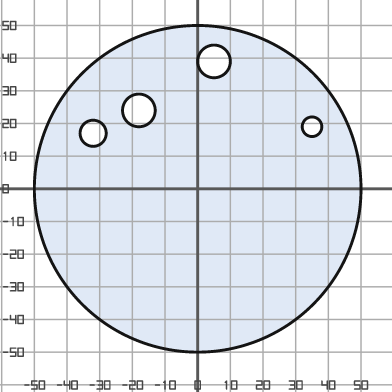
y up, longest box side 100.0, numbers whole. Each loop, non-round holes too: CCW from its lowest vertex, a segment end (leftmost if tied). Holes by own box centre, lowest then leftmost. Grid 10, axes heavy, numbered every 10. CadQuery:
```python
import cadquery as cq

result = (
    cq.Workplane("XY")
    .moveTo(0.0, 0.0)
    .circle(50.0)
    .moveTo(-32.0, 17.0)
    .circle(4.0)
    .moveTo(35.0, 19.0)
    .circle(3.0)
    .moveTo(-18.0, 24.0)
    .circle(5.0)
    .moveTo(5.0, 39.0)
    .circle(5.0)
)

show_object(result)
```